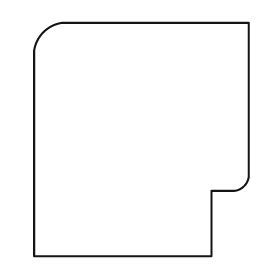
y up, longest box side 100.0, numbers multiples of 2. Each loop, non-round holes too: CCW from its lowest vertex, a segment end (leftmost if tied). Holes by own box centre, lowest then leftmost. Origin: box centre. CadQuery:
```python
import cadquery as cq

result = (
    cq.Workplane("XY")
    .moveTo(-46.0, -50.0)
    .lineTo(30.0, -50.0)
    .lineTo(30.0, -22.0)
    .lineTo(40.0, -22.0)
    .threePointArc((44.0, -20.0), (46.0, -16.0))
    .lineTo(46.0, 50.0)
    .lineTo(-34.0, 50.0)
    .threePointArc((-42.0, 46.0), (-46.0, 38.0))
    .close()
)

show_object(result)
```